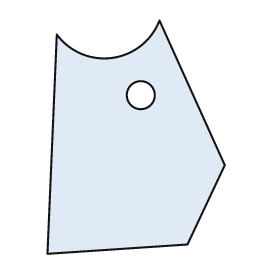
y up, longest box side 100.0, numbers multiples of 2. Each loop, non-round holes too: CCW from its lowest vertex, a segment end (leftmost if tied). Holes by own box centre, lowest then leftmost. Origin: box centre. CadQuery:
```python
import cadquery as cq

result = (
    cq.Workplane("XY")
    .moveTo(-38.0, -50.0)
    .lineTo(22.0, -46.0)
    .lineTo(38.0, -12.0)
    .lineTo(10.0, 50.0)
    .threePointArc((-10.0, 34.0), (-34.0, 44.0))
    .close()
    .moveTo(2.0, 18.0)
    .circle(6.0)
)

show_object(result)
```